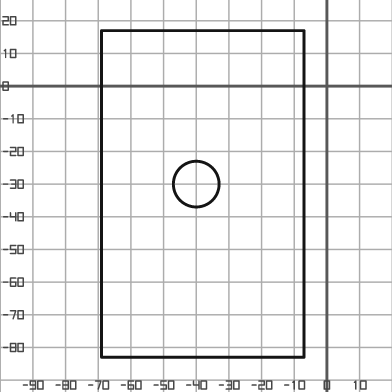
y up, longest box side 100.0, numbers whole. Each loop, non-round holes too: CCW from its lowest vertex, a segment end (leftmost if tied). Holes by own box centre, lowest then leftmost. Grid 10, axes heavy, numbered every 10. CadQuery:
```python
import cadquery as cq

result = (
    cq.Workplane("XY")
    .moveTo(-69.0, -83.0)
    .lineTo(-7.0, -83.0)
    .lineTo(-7.0, 17.0)
    .lineTo(-69.0, 17.0)
    .close()
    .moveTo(-40.0, -30.0)
    .circle(7.0)
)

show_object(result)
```